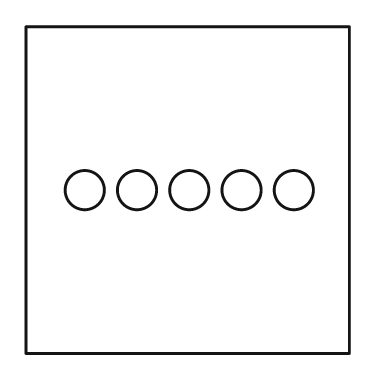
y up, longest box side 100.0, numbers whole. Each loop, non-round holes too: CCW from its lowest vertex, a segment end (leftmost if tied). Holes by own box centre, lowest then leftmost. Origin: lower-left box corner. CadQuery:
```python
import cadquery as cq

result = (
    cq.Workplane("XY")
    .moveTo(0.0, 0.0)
    .lineTo(99.0, 0.0)
    .lineTo(99.0, 100.0)
    .lineTo(0.0, 100.0)
    .close()
    .moveTo(18.0, 50.0)
    .circle(6.0)
    .moveTo(34.0, 50.0)
    .circle(6.0)
    .moveTo(50.0, 50.0)
    .circle(6.0)
    .moveTo(66.0, 50.0)
    .circle(6.0)
    .moveTo(82.0, 50.0)
    .circle(6.0)
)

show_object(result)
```